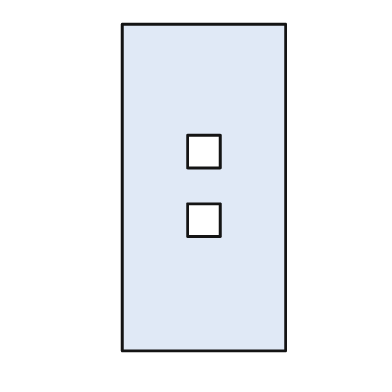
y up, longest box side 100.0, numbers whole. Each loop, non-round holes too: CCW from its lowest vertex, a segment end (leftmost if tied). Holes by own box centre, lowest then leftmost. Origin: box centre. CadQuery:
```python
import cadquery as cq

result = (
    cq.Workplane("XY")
    .moveTo(-25.0, -50.0)
    .lineTo(25.0, -50.0)
    .lineTo(25.0, 50.0)
    .lineTo(-25.0, 50.0)
    .close()
    .moveTo(-5.0, -15.0)
    .lineTo(5.0, -15.0)
    .lineTo(5.0, -5.0)
    .lineTo(-5.0, -5.0)
    .close()
    .moveTo(-5.0, 6.0)
    .lineTo(5.0, 6.0)
    .lineTo(5.0, 16.0)
    .lineTo(-5.0, 16.0)
    .close()
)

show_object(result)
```